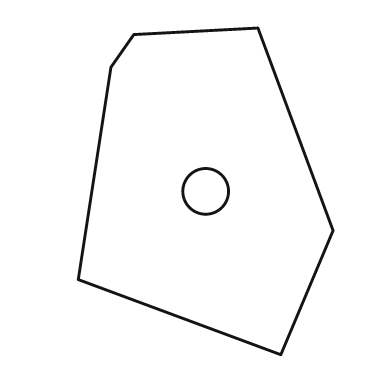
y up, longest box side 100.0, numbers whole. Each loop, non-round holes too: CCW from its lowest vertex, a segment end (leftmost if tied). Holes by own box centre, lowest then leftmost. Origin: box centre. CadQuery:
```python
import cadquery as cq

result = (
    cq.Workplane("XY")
    .moveTo(23.0, -50.0)
    .lineTo(39.0, -12.0)
    .lineTo(16.0, 50.0)
    .lineTo(-22.0, 48.0)
    .lineTo(-29.0, 38.0)
    .lineTo(-39.0, -27.0)
    .close()
    .moveTo(0.0, 0.0)
    .circle(7.0)
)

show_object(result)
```